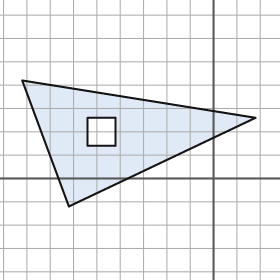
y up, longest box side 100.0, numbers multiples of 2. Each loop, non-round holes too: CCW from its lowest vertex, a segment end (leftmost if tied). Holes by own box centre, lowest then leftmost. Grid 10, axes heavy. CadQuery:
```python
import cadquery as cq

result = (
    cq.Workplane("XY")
    .moveTo(-62.0, -12.0)
    .lineTo(18.0, 26.0)
    .lineTo(-82.0, 42.0)
    .close()
    .moveTo(-54.0, 14.0)
    .lineTo(-42.0, 14.0)
    .lineTo(-42.0, 26.0)
    .lineTo(-54.0, 26.0)
    .close()
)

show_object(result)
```